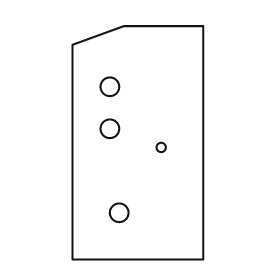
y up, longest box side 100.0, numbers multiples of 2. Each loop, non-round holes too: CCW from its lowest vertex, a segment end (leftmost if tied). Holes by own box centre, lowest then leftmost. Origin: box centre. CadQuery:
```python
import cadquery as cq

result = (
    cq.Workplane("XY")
    .moveTo(-28.0, -50.0)
    .lineTo(28.0, -50.0)
    .lineTo(28.0, 50.0)
    .lineTo(-6.0, 50.0)
    .lineTo(-28.0, 42.0)
    .close()
    .moveTo(-8.0, -30.0)
    .circle(4.0)
    .moveTo(10.0, -2.0)
    .circle(2.0)
    .moveTo(-12.0, 6.0)
    .circle(4.0)
    .moveTo(-12.0, 24.0)
    .circle(4.0)
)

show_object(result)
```